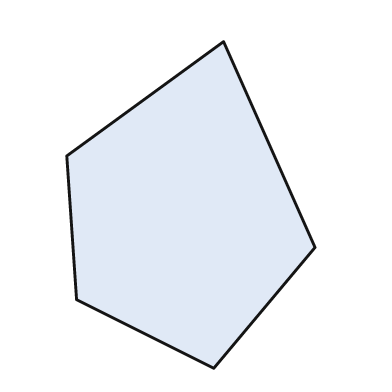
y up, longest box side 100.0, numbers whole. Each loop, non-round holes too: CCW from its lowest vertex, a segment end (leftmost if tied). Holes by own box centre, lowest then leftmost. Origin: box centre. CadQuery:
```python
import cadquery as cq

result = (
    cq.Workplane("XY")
    .moveTo(7.0, -50.0)
    .lineTo(38.0, -13.0)
    .lineTo(10.0, 50.0)
    .lineTo(-38.0, 15.0)
    .lineTo(-35.0, -29.0)
    .close()
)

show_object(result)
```